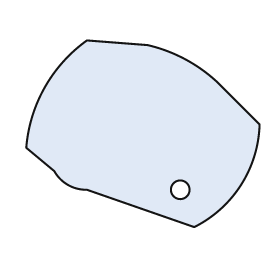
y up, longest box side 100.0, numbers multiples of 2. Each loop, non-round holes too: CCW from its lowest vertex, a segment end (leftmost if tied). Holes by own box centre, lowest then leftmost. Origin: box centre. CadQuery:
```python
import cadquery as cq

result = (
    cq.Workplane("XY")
    .moveTo(22.0, -40.0)
    .threePointArc((42.0, -22.0), (50.0, 4.0))
    .lineTo(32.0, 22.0)
    .threePointArc((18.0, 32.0), (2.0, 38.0))
    .lineTo(-24.0, 40.0)
    .threePointArc((-42.0, 20.0), (-50.0, -6.0))
    .lineTo(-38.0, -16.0)
    .threePointArc((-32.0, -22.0), (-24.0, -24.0))
    .close()
    .moveTo(16.0, -24.0)
    .circle(4.0)
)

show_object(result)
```